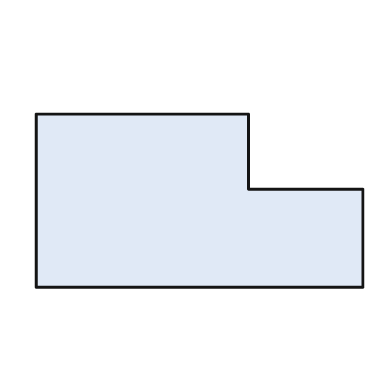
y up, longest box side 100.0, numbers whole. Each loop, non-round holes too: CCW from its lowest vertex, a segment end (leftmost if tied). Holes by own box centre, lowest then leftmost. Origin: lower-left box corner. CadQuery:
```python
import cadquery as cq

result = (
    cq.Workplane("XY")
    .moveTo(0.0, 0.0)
    .lineTo(100.0, 0.0)
    .lineTo(100.0, 30.0)
    .lineTo(65.0, 30.0)
    .lineTo(65.0, 53.0)
    .lineTo(0.0, 53.0)
    .close()
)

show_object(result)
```